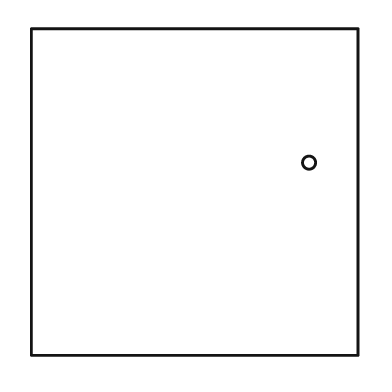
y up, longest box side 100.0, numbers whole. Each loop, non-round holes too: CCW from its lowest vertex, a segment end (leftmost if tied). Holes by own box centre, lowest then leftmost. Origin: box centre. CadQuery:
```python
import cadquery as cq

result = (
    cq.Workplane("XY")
    .moveTo(-50.0, -50.0)
    .lineTo(50.0, -50.0)
    .lineTo(50.0, 50.0)
    .lineTo(-50.0, 50.0)
    .close()
    .moveTo(35.0, 9.0)
    .circle(2.0)
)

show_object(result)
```